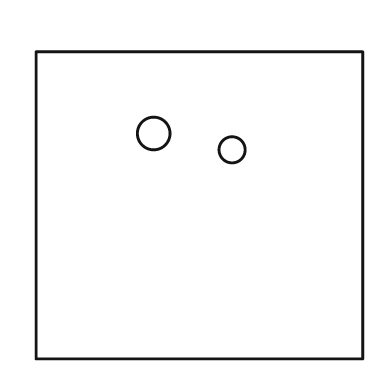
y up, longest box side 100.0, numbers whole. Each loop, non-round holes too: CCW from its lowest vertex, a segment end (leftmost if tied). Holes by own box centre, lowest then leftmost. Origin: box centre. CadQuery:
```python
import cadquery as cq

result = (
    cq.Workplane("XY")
    .moveTo(-50.0, -47.0)
    .lineTo(50.0, -47.0)
    .lineTo(50.0, 47.0)
    .lineTo(-50.0, 47.0)
    .close()
    .moveTo(10.0, 17.0)
    .circle(4.0)
    .moveTo(-14.0, 22.0)
    .circle(5.0)
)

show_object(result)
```